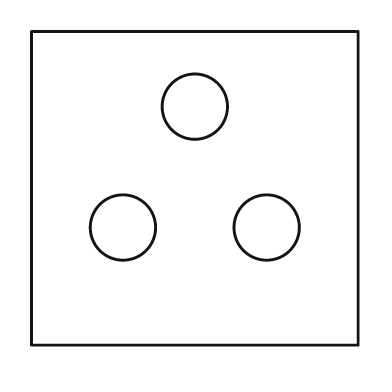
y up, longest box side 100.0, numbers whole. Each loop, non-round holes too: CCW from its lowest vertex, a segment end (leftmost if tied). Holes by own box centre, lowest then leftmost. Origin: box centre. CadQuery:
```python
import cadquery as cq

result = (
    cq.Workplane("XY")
    .moveTo(-50.0, -48.0)
    .lineTo(50.0, -48.0)
    .lineTo(50.0, 48.0)
    .lineTo(-50.0, 48.0)
    .close()
    .moveTo(-22.0, -12.0)
    .circle(10.0)
    .moveTo(22.0, -12.0)
    .circle(10.0)
    .moveTo(0.0, 25.0)
    .circle(10.0)
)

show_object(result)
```